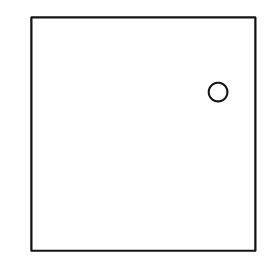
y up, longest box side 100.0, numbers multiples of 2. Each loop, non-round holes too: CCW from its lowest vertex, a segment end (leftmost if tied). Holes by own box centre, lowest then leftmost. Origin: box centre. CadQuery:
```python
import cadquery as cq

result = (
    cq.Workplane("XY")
    .moveTo(-48.0, -50.0)
    .lineTo(48.0, -50.0)
    .lineTo(48.0, 50.0)
    .lineTo(-48.0, 50.0)
    .close()
    .moveTo(32.0, 18.0)
    .circle(4.0)
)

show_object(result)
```